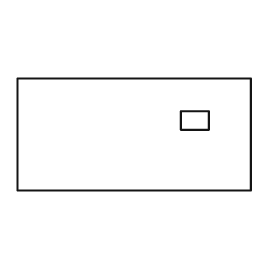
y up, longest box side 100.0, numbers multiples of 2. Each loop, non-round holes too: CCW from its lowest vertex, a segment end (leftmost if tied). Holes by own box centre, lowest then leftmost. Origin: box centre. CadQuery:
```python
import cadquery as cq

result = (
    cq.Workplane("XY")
    .moveTo(-50.0, -24.0)
    .lineTo(50.0, -24.0)
    .lineTo(50.0, 24.0)
    .lineTo(-50.0, 24.0)
    .close()
    .moveTo(20.0, 2.0)
    .lineTo(32.0, 2.0)
    .lineTo(32.0, 10.0)
    .lineTo(20.0, 10.0)
    .close()
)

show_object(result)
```